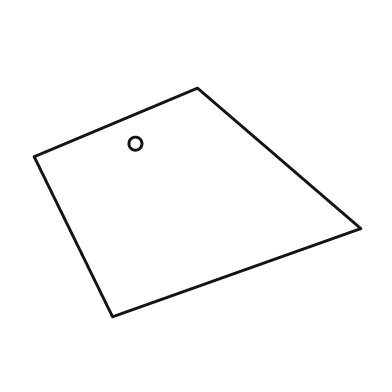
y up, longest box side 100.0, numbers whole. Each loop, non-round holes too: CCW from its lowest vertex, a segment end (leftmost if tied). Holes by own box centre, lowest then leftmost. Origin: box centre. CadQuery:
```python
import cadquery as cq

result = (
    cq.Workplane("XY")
    .moveTo(-26.0, -35.0)
    .lineTo(50.0, -8.0)
    .lineTo(0.0, 35.0)
    .lineTo(-50.0, 14.0)
    .close()
    .moveTo(-19.0, 18.0)
    .circle(2.0)
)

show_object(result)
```